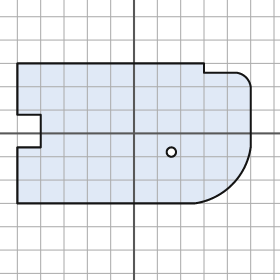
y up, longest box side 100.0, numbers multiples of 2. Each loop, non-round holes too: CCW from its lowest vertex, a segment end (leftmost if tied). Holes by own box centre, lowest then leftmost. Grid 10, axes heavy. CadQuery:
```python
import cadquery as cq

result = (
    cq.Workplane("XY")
    .moveTo(-50.0, -30.0)
    .lineTo(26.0, -30.0)
    .threePointArc((42.0, -22.0), (50.0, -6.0))
    .lineTo(50.0, 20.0)
    .threePointArc((48.0, 24.0), (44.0, 26.0))
    .lineTo(30.0, 26.0)
    .lineTo(30.0, 30.0)
    .lineTo(-50.0, 30.0)
    .lineTo(-50.0, 8.0)
    .lineTo(-40.0, 8.0)
    .lineTo(-40.0, -6.0)
    .lineTo(-50.0, -6.0)
    .close()
    .moveTo(16.0, -8.0)
    .circle(2.0)
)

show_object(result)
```